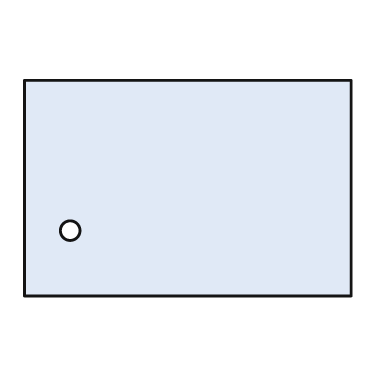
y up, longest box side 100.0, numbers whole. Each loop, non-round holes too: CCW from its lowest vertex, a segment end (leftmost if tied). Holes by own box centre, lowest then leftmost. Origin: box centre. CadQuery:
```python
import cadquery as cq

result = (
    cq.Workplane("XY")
    .moveTo(-50.0, -33.0)
    .lineTo(50.0, -33.0)
    .lineTo(50.0, 33.0)
    .lineTo(-50.0, 33.0)
    .close()
    .moveTo(-36.0, -13.0)
    .circle(3.0)
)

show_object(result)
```